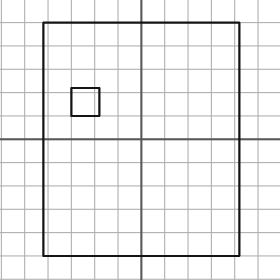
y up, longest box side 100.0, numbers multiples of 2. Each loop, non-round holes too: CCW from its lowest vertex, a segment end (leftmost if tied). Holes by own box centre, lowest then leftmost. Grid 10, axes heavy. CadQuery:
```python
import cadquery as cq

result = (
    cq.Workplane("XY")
    .moveTo(-42.0, -50.0)
    .lineTo(42.0, -50.0)
    .lineTo(42.0, 50.0)
    .lineTo(-42.0, 50.0)
    .close()
    .moveTo(-30.0, 10.0)
    .lineTo(-18.0, 10.0)
    .lineTo(-18.0, 22.0)
    .lineTo(-30.0, 22.0)
    .close()
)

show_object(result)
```